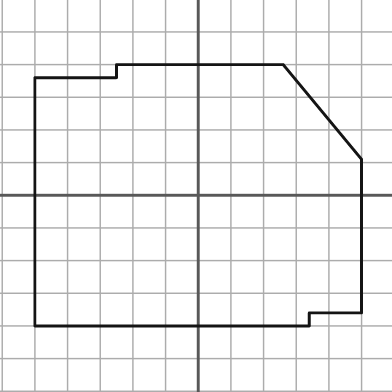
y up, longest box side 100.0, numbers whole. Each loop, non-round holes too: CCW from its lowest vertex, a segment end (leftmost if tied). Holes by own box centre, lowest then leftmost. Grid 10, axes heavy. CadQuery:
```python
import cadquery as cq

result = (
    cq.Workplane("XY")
    .moveTo(-50.0, -40.0)
    .lineTo(34.0, -40.0)
    .lineTo(34.0, -36.0)
    .lineTo(50.0, -36.0)
    .lineTo(50.0, 11.0)
    .lineTo(26.0, 40.0)
    .lineTo(-25.0, 40.0)
    .lineTo(-25.0, 36.0)
    .lineTo(-50.0, 36.0)
    .close()
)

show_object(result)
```